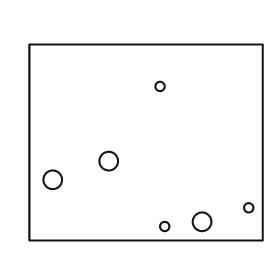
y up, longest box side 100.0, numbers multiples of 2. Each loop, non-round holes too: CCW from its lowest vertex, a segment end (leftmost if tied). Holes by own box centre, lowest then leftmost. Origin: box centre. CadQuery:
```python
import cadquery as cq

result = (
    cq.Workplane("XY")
    .moveTo(-50.0, -42.0)
    .lineTo(50.0, -42.0)
    .lineTo(50.0, 42.0)
    .lineTo(-50.0, 42.0)
    .close()
    .moveTo(8.0, -36.0)
    .circle(2.0)
    .moveTo(24.0, -34.0)
    .circle(4.0)
    .moveTo(44.0, -28.0)
    .circle(2.0)
    .moveTo(-40.0, -16.0)
    .circle(4.0)
    .moveTo(-16.0, -8.0)
    .circle(4.0)
    .moveTo(6.0, 24.0)
    .circle(2.0)
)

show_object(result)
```